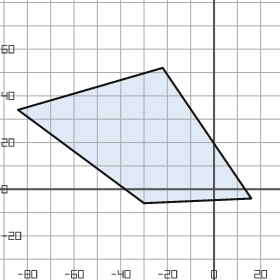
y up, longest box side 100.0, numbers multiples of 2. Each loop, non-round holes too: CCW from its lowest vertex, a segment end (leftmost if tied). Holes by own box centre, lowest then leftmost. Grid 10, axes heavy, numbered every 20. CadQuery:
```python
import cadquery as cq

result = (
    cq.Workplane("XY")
    .moveTo(-30.0, -6.0)
    .lineTo(16.0, -4.0)
    .lineTo(-22.0, 52.0)
    .lineTo(-84.0, 34.0)
    .close()
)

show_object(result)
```